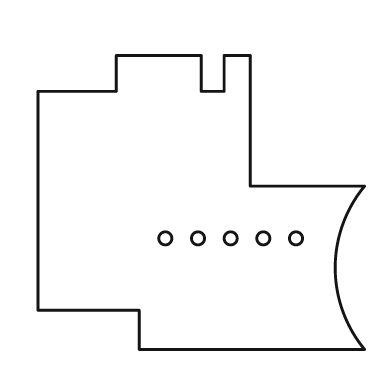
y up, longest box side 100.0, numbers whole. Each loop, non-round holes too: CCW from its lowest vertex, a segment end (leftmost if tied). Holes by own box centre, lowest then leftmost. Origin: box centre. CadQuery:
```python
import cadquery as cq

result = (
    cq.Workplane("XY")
    .moveTo(-19.0, -45.0)
    .lineTo(50.0, -45.0)
    .threePointArc((41.0, -20.0), (50.0, 5.0))
    .lineTo(15.0, 5.0)
    .lineTo(15.0, 45.0)
    .lineTo(7.0, 45.0)
    .lineTo(7.0, 34.0)
    .lineTo(0.0, 34.0)
    .lineTo(0.0, 45.0)
    .lineTo(-26.0, 45.0)
    .lineTo(-26.0, 34.0)
    .lineTo(-50.0, 34.0)
    .lineTo(-50.0, -33.0)
    .lineTo(-19.0, -33.0)
    .close()
    .moveTo(-11.0, -11.0)
    .circle(2.0)
    .moveTo(-1.0, -11.0)
    .circle(2.0)
    .moveTo(9.0, -11.0)
    .circle(2.0)
    .moveTo(19.0, -11.0)
    .circle(2.0)
    .moveTo(29.0, -11.0)
    .circle(2.0)
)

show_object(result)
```